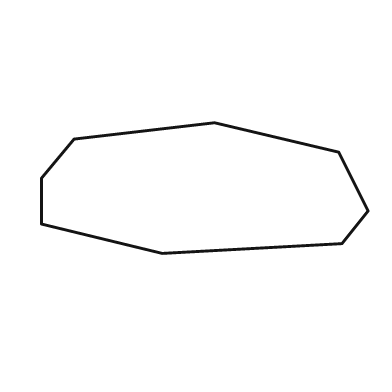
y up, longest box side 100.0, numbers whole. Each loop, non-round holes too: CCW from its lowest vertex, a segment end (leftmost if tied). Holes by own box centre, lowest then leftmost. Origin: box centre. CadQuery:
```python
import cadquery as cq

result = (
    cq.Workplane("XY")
    .moveTo(-13.0, -20.0)
    .lineTo(42.0, -17.0)
    .lineTo(50.0, -7.0)
    .lineTo(41.0, 11.0)
    .lineTo(3.0, 20.0)
    .lineTo(-40.0, 15.0)
    .lineTo(-50.0, 3.0)
    .lineTo(-50.0, -11.0)
    .close()
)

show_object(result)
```